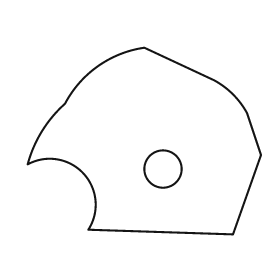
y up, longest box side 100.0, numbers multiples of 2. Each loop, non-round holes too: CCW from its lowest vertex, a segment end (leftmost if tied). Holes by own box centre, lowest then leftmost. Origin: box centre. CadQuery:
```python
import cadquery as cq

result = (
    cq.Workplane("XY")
    .moveTo(38.0, -40.0)
    .lineTo(50.0, -6.0)
    .lineTo(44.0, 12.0)
    .threePointArc((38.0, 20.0), (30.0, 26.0))
    .lineTo(0.0, 40.0)
    .threePointArc((-20.0, 32.0), (-34.0, 16.0))
    .threePointArc((-44.0, 4.0), (-50.0, -10.0))
    .threePointArc((-26.0, -14.0), (-24.0, -38.0))
    .close()
    .moveTo(8.0, -12.0)
    .circle(8.0)
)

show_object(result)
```